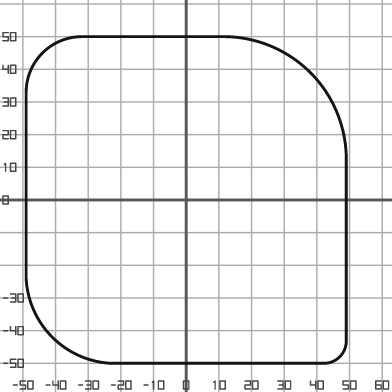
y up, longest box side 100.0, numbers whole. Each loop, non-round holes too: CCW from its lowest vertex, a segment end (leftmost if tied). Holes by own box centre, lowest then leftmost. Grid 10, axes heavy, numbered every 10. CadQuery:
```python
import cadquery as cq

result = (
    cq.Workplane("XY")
    .moveTo(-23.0, -50.0)
    .lineTo(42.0, -50.0)
    .threePointArc((47.0, -48.0), (49.0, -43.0))
    .lineTo(49.0, 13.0)
    .threePointArc((38.0, 39.0), (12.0, 50.0))
    .lineTo(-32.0, 50.0)
    .threePointArc((-44.0, 45.0), (-49.0, 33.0))
    .lineTo(-49.0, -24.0)
    .threePointArc((-41.0, -42.0), (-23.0, -50.0))
    .close()
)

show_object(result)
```